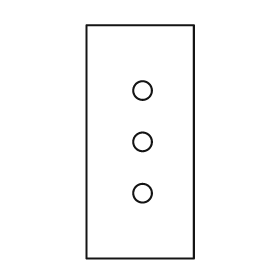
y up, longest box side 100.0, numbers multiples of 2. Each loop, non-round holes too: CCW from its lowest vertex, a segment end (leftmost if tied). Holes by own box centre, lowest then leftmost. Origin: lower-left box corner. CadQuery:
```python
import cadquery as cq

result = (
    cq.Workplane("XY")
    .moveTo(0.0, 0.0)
    .lineTo(46.0, 0.0)
    .lineTo(46.0, 100.0)
    .lineTo(0.0, 100.0)
    .close()
    .moveTo(24.0, 28.0)
    .circle(4.0)
    .moveTo(24.0, 50.0)
    .circle(4.0)
    .moveTo(24.0, 72.0)
    .circle(4.0)
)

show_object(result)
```